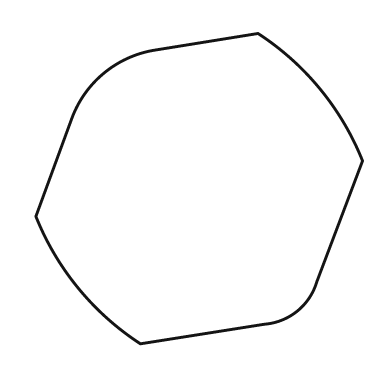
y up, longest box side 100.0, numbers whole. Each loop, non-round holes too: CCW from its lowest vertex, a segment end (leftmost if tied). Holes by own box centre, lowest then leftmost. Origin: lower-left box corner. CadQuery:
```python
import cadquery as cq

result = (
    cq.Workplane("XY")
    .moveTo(32.0, 0.0)
    .lineTo(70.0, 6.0)
    .threePointArc((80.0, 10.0), (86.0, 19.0))
    .lineTo(100.0, 56.0)
    .threePointArc((87.0, 78.0), (68.0, 95.0))
    .lineTo(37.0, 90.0)
    .threePointArc((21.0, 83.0), (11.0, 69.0))
    .lineTo(0.0, 39.0)
    .threePointArc((13.0, 17.0), (32.0, 0.0))
    .close()
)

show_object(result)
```